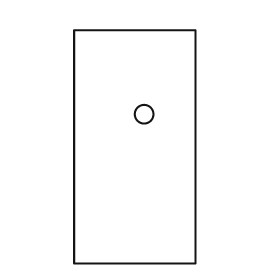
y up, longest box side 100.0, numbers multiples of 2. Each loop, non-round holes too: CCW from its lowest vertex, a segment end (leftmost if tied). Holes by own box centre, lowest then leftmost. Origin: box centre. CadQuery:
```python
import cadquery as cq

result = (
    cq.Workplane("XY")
    .moveTo(-26.0, -50.0)
    .lineTo(26.0, -50.0)
    .lineTo(26.0, 50.0)
    .lineTo(-26.0, 50.0)
    .close()
    .moveTo(4.0, 14.0)
    .circle(4.0)
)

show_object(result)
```